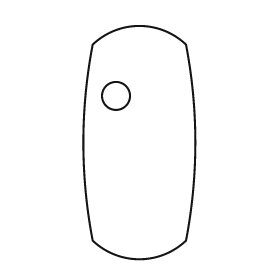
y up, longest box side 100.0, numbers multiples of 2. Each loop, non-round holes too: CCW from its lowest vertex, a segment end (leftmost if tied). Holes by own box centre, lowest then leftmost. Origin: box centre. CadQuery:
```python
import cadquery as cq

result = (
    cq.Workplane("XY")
    .moveTo(-20.0, -42.0)
    .threePointArc((0.0, -50.0), (20.0, -42.0))
    .threePointArc((24.0, 0.0), (20.0, 42.0))
    .threePointArc((0.0, 50.0), (-20.0, 42.0))
    .threePointArc((-24.0, 0.0), (-20.0, -42.0))
    .close()
    .moveTo(-10.0, 20.0)
    .circle(6.0)
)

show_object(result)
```